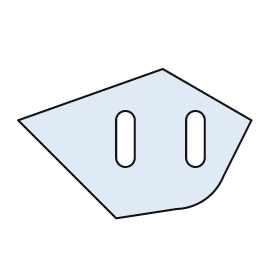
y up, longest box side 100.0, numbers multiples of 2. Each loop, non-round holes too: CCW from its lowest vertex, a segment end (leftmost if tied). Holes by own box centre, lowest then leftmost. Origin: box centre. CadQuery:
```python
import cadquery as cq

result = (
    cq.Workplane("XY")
    .moveTo(-8.0, -32.0)
    .lineTo(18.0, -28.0)
    .threePointArc((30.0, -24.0), (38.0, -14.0))
    .lineTo(50.0, 10.0)
    .lineTo(12.0, 32.0)
    .lineTo(-50.0, 10.0)
    .close()
    .moveTo(-8.0, -6.0)
    .threePointArc((-4.0, -10.0), (0.0, -6.0))
    .lineTo(0.0, 10.0)
    .threePointArc((-4.0, 14.0), (-8.0, 10.0))
    .close()
    .moveTo(22.0, -6.0)
    .threePointArc((26.0, -10.0), (30.0, -6.0))
    .lineTo(30.0, 10.0)
    .threePointArc((26.0, 14.0), (22.0, 10.0))
    .close()
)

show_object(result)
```